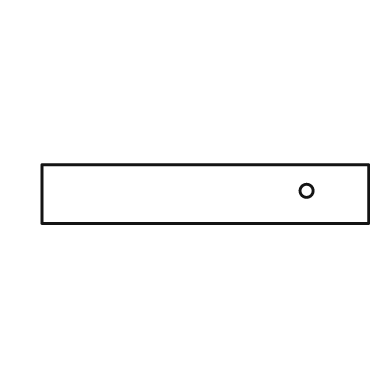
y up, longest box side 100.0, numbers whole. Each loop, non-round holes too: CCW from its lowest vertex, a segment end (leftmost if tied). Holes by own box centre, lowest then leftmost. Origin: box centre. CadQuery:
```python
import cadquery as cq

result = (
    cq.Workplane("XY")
    .moveTo(-50.0, -9.0)
    .lineTo(50.0, -9.0)
    .lineTo(50.0, 9.0)
    .lineTo(-50.0, 9.0)
    .close()
    .moveTo(31.0, 1.0)
    .circle(2.0)
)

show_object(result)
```